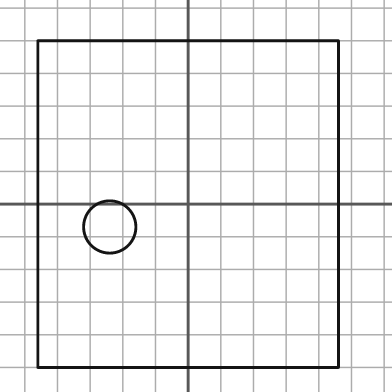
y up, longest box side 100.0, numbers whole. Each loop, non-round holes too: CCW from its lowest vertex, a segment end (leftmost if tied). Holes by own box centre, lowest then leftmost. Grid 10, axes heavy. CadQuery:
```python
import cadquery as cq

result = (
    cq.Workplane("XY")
    .moveTo(-46.0, -50.0)
    .lineTo(46.0, -50.0)
    .lineTo(46.0, 50.0)
    .lineTo(-46.0, 50.0)
    .close()
    .moveTo(-24.0, -7.0)
    .circle(8.0)
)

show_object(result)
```